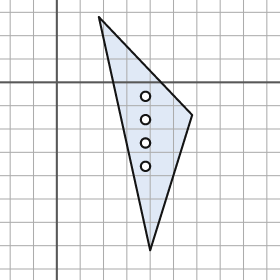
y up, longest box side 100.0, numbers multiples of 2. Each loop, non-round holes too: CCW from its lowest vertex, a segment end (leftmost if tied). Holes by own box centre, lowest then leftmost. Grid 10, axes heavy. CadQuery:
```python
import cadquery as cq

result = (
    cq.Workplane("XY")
    .moveTo(40.0, -72.0)
    .lineTo(58.0, -14.0)
    .lineTo(18.0, 28.0)
    .close()
    .moveTo(38.0, -36.0)
    .circle(2.0)
    .moveTo(38.0, -26.0)
    .circle(2.0)
    .moveTo(38.0, -16.0)
    .circle(2.0)
    .moveTo(38.0, -6.0)
    .circle(2.0)
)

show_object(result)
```